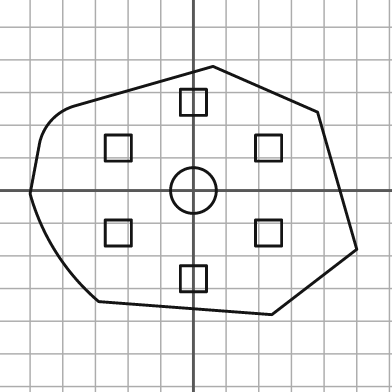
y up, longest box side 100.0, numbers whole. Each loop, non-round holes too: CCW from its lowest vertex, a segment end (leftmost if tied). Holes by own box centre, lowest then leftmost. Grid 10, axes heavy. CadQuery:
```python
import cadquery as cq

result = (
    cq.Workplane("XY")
    .moveTo(24.0, -38.0)
    .lineTo(50.0, -18.0)
    .lineTo(38.0, 24.0)
    .lineTo(6.0, 38.0)
    .lineTo(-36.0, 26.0)
    .threePointArc((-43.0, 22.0), (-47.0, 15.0))
    .lineTo(-50.0, -1.0)
    .threePointArc((-42.0, -19.0), (-29.0, -34.0))
    .close()
    .moveTo(-4.0, -31.0)
    .lineTo(4.0, -31.0)
    .lineTo(4.0, -23.0)
    .lineTo(-4.0, -23.0)
    .close()
    .moveTo(-27.0, -17.0)
    .lineTo(-19.0, -17.0)
    .lineTo(-19.0, -9.0)
    .lineTo(-27.0, -9.0)
    .close()
    .moveTo(19.0, -17.0)
    .lineTo(27.0, -17.0)
    .lineTo(27.0, -9.0)
    .lineTo(19.0, -9.0)
    .close()
    .moveTo(0.0, 0.0)
    .circle(7.0)
    .moveTo(-27.0, 9.0)
    .lineTo(-19.0, 9.0)
    .lineTo(-19.0, 17.0)
    .lineTo(-27.0, 17.0)
    .close()
    .moveTo(19.0, 9.0)
    .lineTo(27.0, 9.0)
    .lineTo(27.0, 17.0)
    .lineTo(19.0, 17.0)
    .close()
    .moveTo(-4.0, 23.0)
    .lineTo(4.0, 23.0)
    .lineTo(4.0, 31.0)
    .lineTo(-4.0, 31.0)
    .close()
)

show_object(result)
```